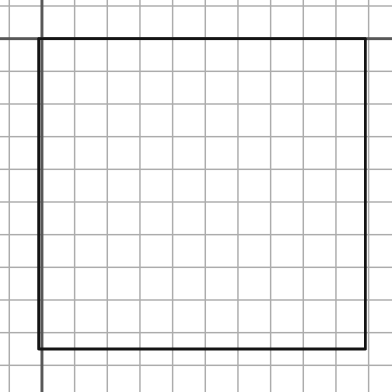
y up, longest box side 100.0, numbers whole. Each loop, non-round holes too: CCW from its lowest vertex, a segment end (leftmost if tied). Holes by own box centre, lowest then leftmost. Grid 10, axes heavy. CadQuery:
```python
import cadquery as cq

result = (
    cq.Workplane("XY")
    .moveTo(-1.0, -95.0)
    .lineTo(99.0, -95.0)
    .lineTo(99.0, 0.0)
    .lineTo(-1.0, 0.0)
    .close()
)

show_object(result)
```